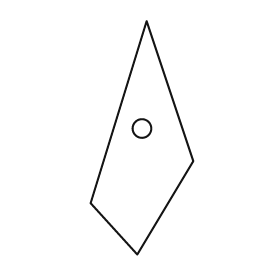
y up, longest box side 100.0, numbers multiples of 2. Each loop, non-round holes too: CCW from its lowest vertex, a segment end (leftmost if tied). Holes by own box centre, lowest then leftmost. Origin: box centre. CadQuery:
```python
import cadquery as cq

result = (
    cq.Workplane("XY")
    .moveTo(-2.0, -50.0)
    .lineTo(22.0, -10.0)
    .lineTo(2.0, 50.0)
    .lineTo(-22.0, -28.0)
    .close()
    .moveTo(0.0, 4.0)
    .circle(4.0)
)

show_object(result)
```